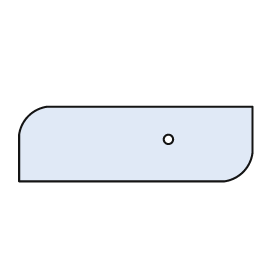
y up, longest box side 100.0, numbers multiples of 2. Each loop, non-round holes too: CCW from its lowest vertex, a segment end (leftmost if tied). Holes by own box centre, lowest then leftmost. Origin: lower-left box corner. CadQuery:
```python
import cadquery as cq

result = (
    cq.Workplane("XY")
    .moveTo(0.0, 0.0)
    .lineTo(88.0, 0.0)
    .threePointArc((96.0, 4.0), (100.0, 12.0))
    .lineTo(100.0, 32.0)
    .lineTo(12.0, 32.0)
    .threePointArc((4.0, 28.0), (0.0, 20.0))
    .close()
    .moveTo(64.0, 18.0)
    .circle(2.0)
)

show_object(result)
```